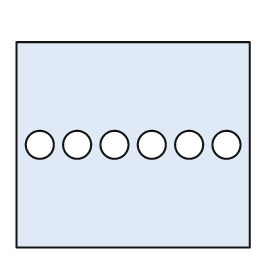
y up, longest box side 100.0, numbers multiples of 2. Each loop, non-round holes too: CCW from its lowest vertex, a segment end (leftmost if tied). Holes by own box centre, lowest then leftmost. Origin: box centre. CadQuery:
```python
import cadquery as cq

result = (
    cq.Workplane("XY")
    .moveTo(-50.0, -44.0)
    .lineTo(50.0, -44.0)
    .lineTo(50.0, 44.0)
    .lineTo(-50.0, 44.0)
    .close()
    .moveTo(-40.0, 0.0)
    .circle(6.0)
    .moveTo(-24.0, 0.0)
    .circle(6.0)
    .moveTo(-8.0, 0.0)
    .circle(6.0)
    .moveTo(8.0, 0.0)
    .circle(6.0)
    .moveTo(24.0, 0.0)
    .circle(6.0)
    .moveTo(40.0, 0.0)
    .circle(6.0)
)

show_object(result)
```